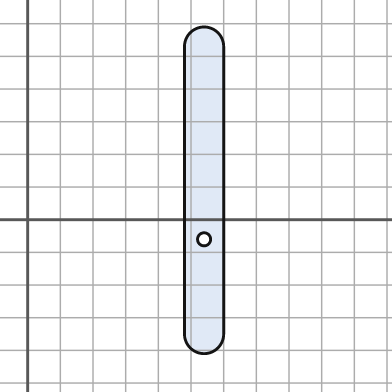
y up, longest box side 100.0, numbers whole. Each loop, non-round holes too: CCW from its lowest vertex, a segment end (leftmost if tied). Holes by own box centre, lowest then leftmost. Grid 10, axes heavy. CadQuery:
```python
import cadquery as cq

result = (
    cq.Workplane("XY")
    .moveTo(48.0, -35.0)
    .threePointArc((54.0, -41.0), (60.0, -35.0))
    .lineTo(60.0, 53.0)
    .threePointArc((54.0, 59.0), (48.0, 53.0))
    .close()
    .moveTo(54.0, -6.0)
    .circle(2.0)
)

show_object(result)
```